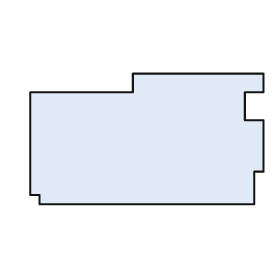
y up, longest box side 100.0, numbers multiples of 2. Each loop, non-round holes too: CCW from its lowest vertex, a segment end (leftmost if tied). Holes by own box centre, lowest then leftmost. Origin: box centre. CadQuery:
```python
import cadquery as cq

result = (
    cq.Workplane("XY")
    .moveTo(-46.0, -28.0)
    .lineTo(46.0, -28.0)
    .lineTo(46.0, -14.0)
    .lineTo(50.0, -14.0)
    .lineTo(50.0, 8.0)
    .lineTo(42.0, 8.0)
    .lineTo(42.0, 20.0)
    .lineTo(50.0, 20.0)
    .lineTo(50.0, 28.0)
    .lineTo(-6.0, 28.0)
    .lineTo(-6.0, 20.0)
    .lineTo(-50.0, 20.0)
    .lineTo(-50.0, -24.0)
    .lineTo(-46.0, -24.0)
    .close()
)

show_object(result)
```